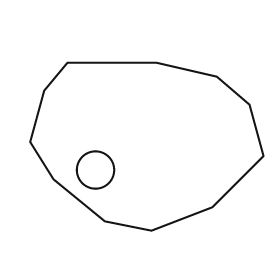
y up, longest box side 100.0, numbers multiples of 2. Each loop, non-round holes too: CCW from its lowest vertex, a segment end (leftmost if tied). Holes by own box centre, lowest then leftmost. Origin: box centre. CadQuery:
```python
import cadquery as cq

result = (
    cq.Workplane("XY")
    .moveTo(2.0, -36.0)
    .lineTo(28.0, -26.0)
    .lineTo(50.0, -4.0)
    .lineTo(44.0, 18.0)
    .lineTo(30.0, 30.0)
    .lineTo(4.0, 36.0)
    .lineTo(-34.0, 36.0)
    .lineTo(-44.0, 24.0)
    .lineTo(-50.0, 2.0)
    .lineTo(-40.0, -14.0)
    .lineTo(-18.0, -32.0)
    .close()
    .moveTo(-22.0, -10.0)
    .circle(8.0)
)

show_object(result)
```